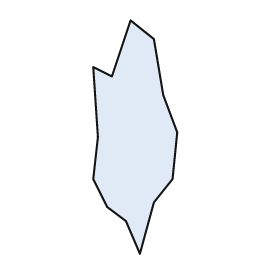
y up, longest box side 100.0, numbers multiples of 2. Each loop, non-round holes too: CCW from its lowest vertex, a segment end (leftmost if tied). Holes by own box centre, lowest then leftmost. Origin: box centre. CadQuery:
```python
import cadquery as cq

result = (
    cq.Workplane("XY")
    .moveTo(2.0, -50.0)
    .lineTo(8.0, -28.0)
    .lineTo(16.0, -18.0)
    .lineTo(18.0, 2.0)
    .lineTo(12.0, 18.0)
    .lineTo(8.0, 42.0)
    .lineTo(-2.0, 50.0)
    .lineTo(-10.0, 26.0)
    .lineTo(-18.0, 30.0)
    .lineTo(-16.0, 0.0)
    .lineTo(-18.0, -18.0)
    .lineTo(-12.0, -30.0)
    .lineTo(-4.0, -36.0)
    .close()
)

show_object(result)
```